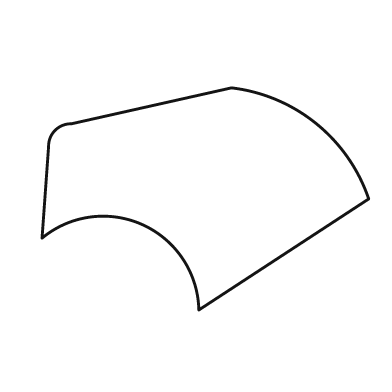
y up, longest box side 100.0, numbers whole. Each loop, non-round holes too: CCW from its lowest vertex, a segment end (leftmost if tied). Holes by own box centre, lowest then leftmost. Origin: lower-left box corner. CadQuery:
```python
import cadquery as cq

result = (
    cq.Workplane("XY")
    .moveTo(48.0, 0.0)
    .lineTo(100.0, 34.0)
    .threePointArc((84.0, 57.0), (58.0, 68.0))
    .lineTo(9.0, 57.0)
    .threePointArc((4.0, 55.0), (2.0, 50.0))
    .lineTo(0.0, 22.0)
    .threePointArc((31.0, 26.0), (48.0, 0.0))
    .close()
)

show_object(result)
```